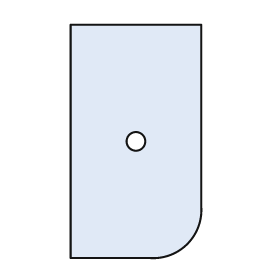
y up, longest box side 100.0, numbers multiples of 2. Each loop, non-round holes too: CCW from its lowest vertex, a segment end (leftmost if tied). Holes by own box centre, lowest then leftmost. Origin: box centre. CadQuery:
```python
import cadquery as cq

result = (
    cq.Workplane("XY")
    .moveTo(-28.0, -50.0)
    .lineTo(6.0, -50.0)
    .threePointArc((22.0, -44.0), (28.0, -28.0))
    .lineTo(28.0, 50.0)
    .lineTo(-28.0, 50.0)
    .close()
    .moveTo(0.0, 0.0)
    .circle(4.0)
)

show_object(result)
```